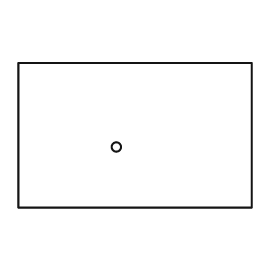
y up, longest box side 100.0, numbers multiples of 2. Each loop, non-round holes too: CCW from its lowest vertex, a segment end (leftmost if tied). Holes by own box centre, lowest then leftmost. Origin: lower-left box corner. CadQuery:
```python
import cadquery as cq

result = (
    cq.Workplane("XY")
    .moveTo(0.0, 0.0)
    .lineTo(100.0, 0.0)
    .lineTo(100.0, 62.0)
    .lineTo(0.0, 62.0)
    .close()
    .moveTo(42.0, 26.0)
    .circle(2.0)
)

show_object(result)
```